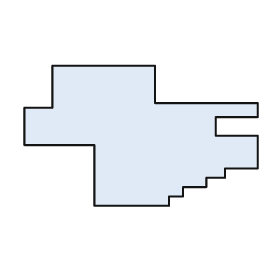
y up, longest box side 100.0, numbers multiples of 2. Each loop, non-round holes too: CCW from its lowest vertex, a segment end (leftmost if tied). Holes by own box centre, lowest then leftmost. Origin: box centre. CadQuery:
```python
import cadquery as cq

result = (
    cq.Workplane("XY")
    .moveTo(-20.0, -30.0)
    .lineTo(12.0, -30.0)
    .lineTo(12.0, -26.0)
    .lineTo(18.0, -26.0)
    .lineTo(18.0, -22.0)
    .lineTo(28.0, -22.0)
    .lineTo(28.0, -18.0)
    .lineTo(36.0, -18.0)
    .lineTo(36.0, -14.0)
    .lineTo(50.0, -14.0)
    .lineTo(50.0, 0.0)
    .lineTo(32.0, 0.0)
    .lineTo(32.0, 8.0)
    .lineTo(50.0, 8.0)
    .lineTo(50.0, 14.0)
    .lineTo(6.0, 14.0)
    .lineTo(6.0, 30.0)
    .lineTo(-38.0, 30.0)
    .lineTo(-38.0, 12.0)
    .lineTo(-50.0, 12.0)
    .lineTo(-50.0, -4.0)
    .lineTo(-20.0, -4.0)
    .close()
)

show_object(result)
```